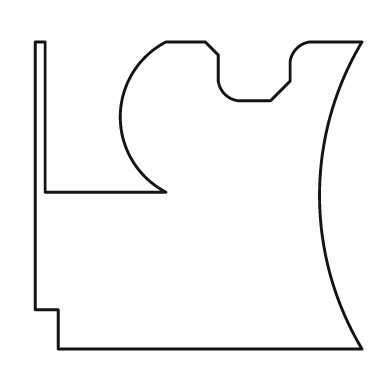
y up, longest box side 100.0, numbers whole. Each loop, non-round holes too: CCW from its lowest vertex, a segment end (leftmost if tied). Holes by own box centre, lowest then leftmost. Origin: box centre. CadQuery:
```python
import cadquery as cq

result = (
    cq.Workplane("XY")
    .moveTo(-43.0, -47.0)
    .lineTo(50.0, -47.0)
    .threePointArc((37.0, 0.0), (50.0, 47.0))
    .lineTo(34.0, 47.0)
    .threePointArc((30.0, 45.0), (28.0, 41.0))
    .lineTo(28.0, 35.0)
    .lineTo(22.0, 29.0)
    .lineTo(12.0, 29.0)
    .threePointArc((8.0, 31.0), (6.0, 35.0))
    .lineTo(6.0, 43.0)
    .lineTo(2.0, 47.0)
    .lineTo(-10.0, 47.0)
    .threePointArc((-24.0, 24.0), (-10.0, 1.0))
    .lineTo(-47.0, 1.0)
    .lineTo(-47.0, 47.0)
    .lineTo(-50.0, 47.0)
    .lineTo(-50.0, -35.0)
    .lineTo(-43.0, -35.0)
    .close()
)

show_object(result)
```